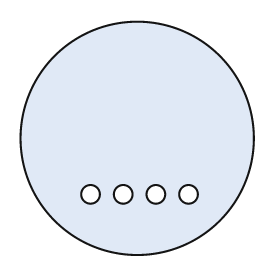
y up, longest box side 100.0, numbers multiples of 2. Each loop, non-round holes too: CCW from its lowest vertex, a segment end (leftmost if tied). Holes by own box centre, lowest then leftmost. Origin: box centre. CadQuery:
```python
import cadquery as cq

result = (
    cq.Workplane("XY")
    .moveTo(0.0, 0.0)
    .circle(50.0)
    .moveTo(-20.0, -24.0)
    .circle(4.0)
    .moveTo(-6.0, -24.0)
    .circle(4.0)
    .moveTo(8.0, -24.0)
    .circle(4.0)
    .moveTo(22.0, -24.0)
    .circle(4.0)
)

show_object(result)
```